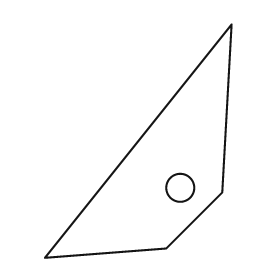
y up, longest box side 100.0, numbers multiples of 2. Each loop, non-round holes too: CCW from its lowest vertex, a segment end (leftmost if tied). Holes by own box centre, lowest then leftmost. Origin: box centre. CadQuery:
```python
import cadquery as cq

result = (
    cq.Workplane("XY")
    .moveTo(-40.0, -50.0)
    .lineTo(12.0, -46.0)
    .lineTo(36.0, -22.0)
    .lineTo(40.0, 50.0)
    .close()
    .moveTo(18.0, -20.0)
    .circle(6.0)
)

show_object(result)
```